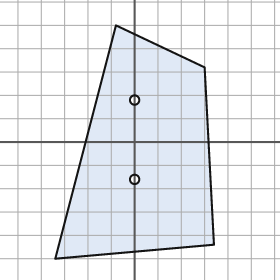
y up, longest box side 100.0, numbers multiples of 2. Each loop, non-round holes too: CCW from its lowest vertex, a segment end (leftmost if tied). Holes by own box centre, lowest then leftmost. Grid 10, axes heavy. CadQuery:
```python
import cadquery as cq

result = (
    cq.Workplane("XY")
    .moveTo(-34.0, -50.0)
    .lineTo(34.0, -44.0)
    .lineTo(30.0, 32.0)
    .lineTo(-8.0, 50.0)
    .close()
    .moveTo(0.0, -16.0)
    .circle(2.0)
    .moveTo(0.0, 18.0)
    .circle(2.0)
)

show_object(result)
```